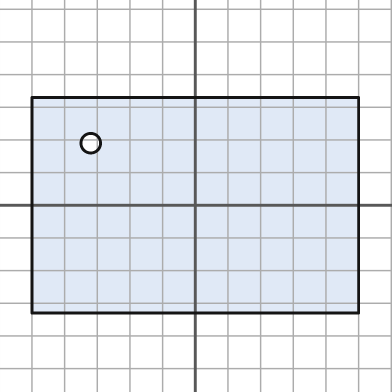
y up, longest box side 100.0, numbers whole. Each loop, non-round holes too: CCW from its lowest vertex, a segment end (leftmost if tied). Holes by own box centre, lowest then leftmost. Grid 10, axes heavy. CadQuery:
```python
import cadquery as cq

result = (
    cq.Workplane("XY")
    .moveTo(-50.0, -33.0)
    .lineTo(50.0, -33.0)
    .lineTo(50.0, 33.0)
    .lineTo(-50.0, 33.0)
    .close()
    .moveTo(-32.0, 19.0)
    .circle(3.0)
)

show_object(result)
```